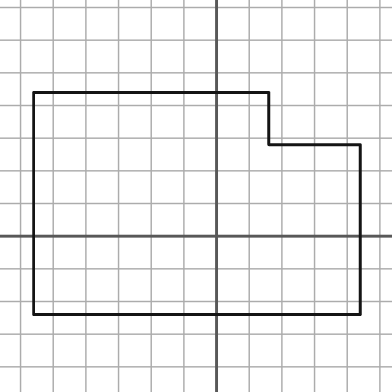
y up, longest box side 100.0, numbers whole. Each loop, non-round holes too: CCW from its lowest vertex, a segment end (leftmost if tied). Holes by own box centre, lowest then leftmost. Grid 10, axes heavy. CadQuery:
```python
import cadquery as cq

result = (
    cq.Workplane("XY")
    .moveTo(-56.0, -24.0)
    .lineTo(44.0, -24.0)
    .lineTo(44.0, 28.0)
    .lineTo(16.0, 28.0)
    .lineTo(16.0, 44.0)
    .lineTo(-56.0, 44.0)
    .close()
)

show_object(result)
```